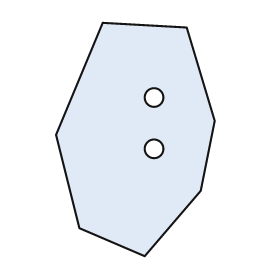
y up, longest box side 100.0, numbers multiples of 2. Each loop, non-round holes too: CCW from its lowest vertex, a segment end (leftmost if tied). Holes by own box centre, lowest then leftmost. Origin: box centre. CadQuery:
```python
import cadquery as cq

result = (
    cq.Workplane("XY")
    .moveTo(4.0, -50.0)
    .lineTo(28.0, -22.0)
    .lineTo(34.0, 8.0)
    .lineTo(22.0, 48.0)
    .lineTo(-14.0, 50.0)
    .lineTo(-34.0, 2.0)
    .lineTo(-24.0, -38.0)
    .close()
    .moveTo(8.0, -4.0)
    .circle(4.0)
    .moveTo(8.0, 18.0)
    .circle(4.0)
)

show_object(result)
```